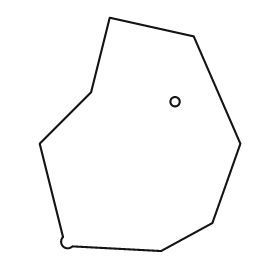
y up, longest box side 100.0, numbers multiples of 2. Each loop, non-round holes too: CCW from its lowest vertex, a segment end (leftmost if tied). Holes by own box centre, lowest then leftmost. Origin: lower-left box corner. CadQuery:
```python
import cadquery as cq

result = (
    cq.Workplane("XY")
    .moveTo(52.0, 0.0)
    .lineTo(74.0, 12.0)
    .lineTo(86.0, 46.0)
    .lineTo(66.0, 92.0)
    .lineTo(30.0, 100.0)
    .lineTo(22.0, 68.0)
    .lineTo(0.0, 46.0)
    .lineTo(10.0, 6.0)
    .threePointArc((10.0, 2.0), (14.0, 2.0))
    .close()
    .moveTo(58.0, 64.0)
    .circle(2.0)
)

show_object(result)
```